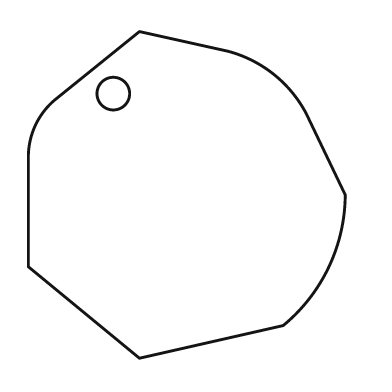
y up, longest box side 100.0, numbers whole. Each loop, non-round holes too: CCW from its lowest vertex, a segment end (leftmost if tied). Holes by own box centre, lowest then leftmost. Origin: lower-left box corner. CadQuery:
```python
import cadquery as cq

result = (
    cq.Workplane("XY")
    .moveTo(34.0, 0.0)
    .lineTo(78.0, 10.0)
    .threePointArc((92.0, 28.0), (97.0, 50.0))
    .lineTo(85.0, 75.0)
    .threePointArc((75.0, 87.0), (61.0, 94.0))
    .lineTo(34.0, 100.0)
    .lineTo(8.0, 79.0)
    .threePointArc((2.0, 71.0), (0.0, 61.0))
    .lineTo(0.0, 28.0)
    .close()
    .moveTo(26.0, 81.0)
    .circle(5.0)
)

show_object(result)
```